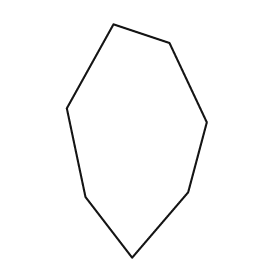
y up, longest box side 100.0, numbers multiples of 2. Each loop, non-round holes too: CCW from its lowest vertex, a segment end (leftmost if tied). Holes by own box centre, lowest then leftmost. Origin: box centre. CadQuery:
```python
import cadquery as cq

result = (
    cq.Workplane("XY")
    .moveTo(-2.0, -50.0)
    .lineTo(22.0, -22.0)
    .lineTo(30.0, 8.0)
    .lineTo(14.0, 42.0)
    .lineTo(-10.0, 50.0)
    .lineTo(-30.0, 14.0)
    .lineTo(-22.0, -24.0)
    .close()
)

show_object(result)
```